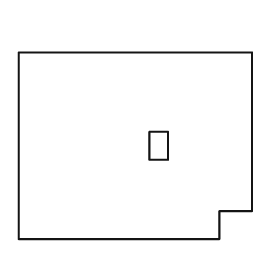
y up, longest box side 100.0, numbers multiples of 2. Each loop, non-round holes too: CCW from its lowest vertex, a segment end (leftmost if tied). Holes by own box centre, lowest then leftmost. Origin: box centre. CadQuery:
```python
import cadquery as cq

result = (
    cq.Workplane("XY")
    .moveTo(-50.0, -40.0)
    .lineTo(36.0, -40.0)
    .lineTo(36.0, -28.0)
    .lineTo(50.0, -28.0)
    .lineTo(50.0, 40.0)
    .lineTo(-50.0, 40.0)
    .close()
    .moveTo(6.0, -6.0)
    .lineTo(14.0, -6.0)
    .lineTo(14.0, 6.0)
    .lineTo(6.0, 6.0)
    .close()
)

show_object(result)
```